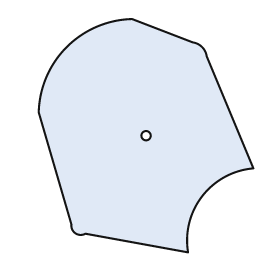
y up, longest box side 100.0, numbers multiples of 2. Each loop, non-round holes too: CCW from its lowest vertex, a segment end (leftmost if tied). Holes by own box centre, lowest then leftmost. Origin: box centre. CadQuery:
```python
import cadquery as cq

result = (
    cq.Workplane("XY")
    .moveTo(18.0, -50.0)
    .threePointArc((24.0, -26.0), (46.0, -14.0))
    .lineTo(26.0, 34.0)
    .threePointArc((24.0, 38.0), (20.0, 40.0))
    .lineTo(-6.0, 50.0)
    .threePointArc((-34.0, 38.0), (-46.0, 10.0))
    .lineTo(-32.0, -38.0)
    .threePointArc((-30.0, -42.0), (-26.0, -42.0))
    .close()
    .moveTo(0.0, 0.0)
    .circle(2.0)
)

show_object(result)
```